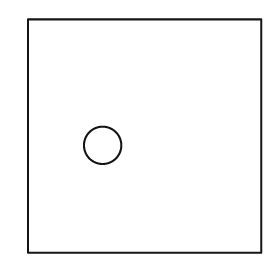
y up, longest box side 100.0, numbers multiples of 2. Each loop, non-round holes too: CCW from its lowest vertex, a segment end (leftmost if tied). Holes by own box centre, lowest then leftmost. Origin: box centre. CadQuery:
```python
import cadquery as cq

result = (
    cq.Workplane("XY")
    .moveTo(-50.0, -50.0)
    .lineTo(50.0, -50.0)
    .lineTo(50.0, 50.0)
    .lineTo(-50.0, 50.0)
    .close()
    .moveTo(-18.0, -4.0)
    .circle(8.0)
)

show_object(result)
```